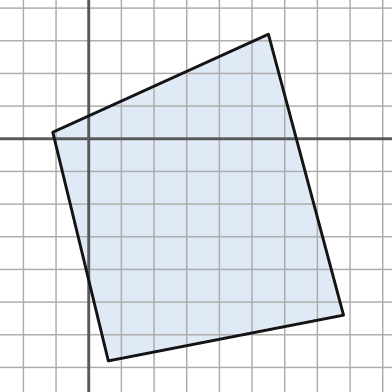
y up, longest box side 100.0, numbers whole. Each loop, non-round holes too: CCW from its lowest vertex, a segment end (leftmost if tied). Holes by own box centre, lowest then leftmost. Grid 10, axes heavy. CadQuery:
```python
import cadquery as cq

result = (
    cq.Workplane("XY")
    .moveTo(6.0, -68.0)
    .lineTo(78.0, -54.0)
    .lineTo(55.0, 32.0)
    .lineTo(-11.0, 2.0)
    .close()
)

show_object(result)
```